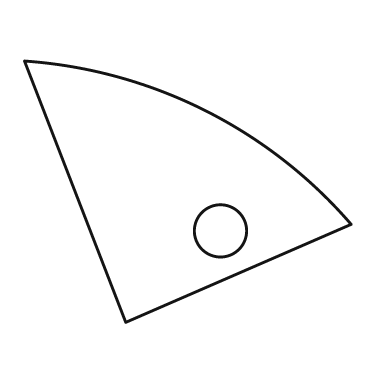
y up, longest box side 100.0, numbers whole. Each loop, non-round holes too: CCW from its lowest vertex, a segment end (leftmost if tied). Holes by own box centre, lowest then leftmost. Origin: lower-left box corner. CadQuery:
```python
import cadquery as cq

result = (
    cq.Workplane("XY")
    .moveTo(31.0, 0.0)
    .lineTo(100.0, 30.0)
    .threePointArc((55.0, 65.0), (0.0, 80.0))
    .close()
    .moveTo(60.0, 28.0)
    .circle(8.0)
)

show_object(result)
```